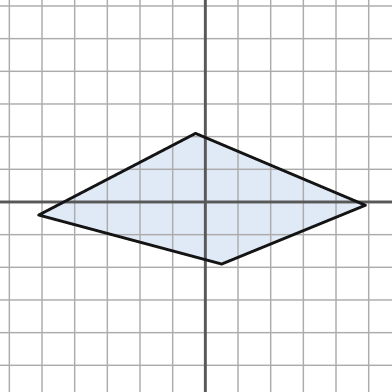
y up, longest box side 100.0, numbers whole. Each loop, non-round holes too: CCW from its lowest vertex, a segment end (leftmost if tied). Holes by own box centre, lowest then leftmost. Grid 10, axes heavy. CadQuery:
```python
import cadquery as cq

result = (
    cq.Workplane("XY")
    .moveTo(5.0, -19.0)
    .lineTo(49.0, -1.0)
    .lineTo(-3.0, 21.0)
    .lineTo(-51.0, -4.0)
    .close()
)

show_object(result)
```